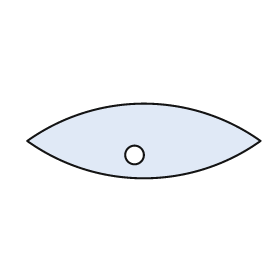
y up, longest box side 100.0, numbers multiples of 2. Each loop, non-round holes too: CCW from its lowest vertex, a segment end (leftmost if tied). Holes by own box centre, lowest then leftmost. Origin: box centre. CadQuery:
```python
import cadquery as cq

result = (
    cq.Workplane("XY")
    .moveTo(-50.0, 0.0)
    .threePointArc((0.0, -16.0), (50.0, 0.0))
    .threePointArc((0.0, 16.0), (-50.0, 0.0))
    .close()
    .moveTo(-4.0, -6.0)
    .circle(4.0)
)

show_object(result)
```